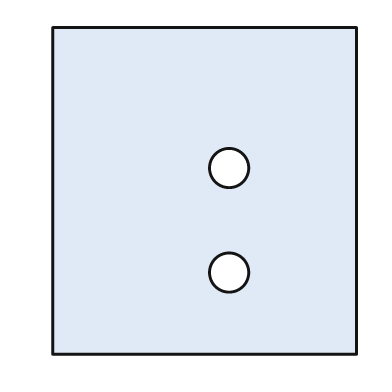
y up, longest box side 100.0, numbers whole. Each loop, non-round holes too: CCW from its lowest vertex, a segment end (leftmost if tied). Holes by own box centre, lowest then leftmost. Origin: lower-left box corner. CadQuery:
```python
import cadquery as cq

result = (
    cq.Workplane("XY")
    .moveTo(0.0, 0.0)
    .lineTo(93.0, 0.0)
    .lineTo(93.0, 100.0)
    .lineTo(0.0, 100.0)
    .close()
    .moveTo(54.0, 25.0)
    .circle(6.0)
    .moveTo(54.0, 57.0)
    .circle(6.0)
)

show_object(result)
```